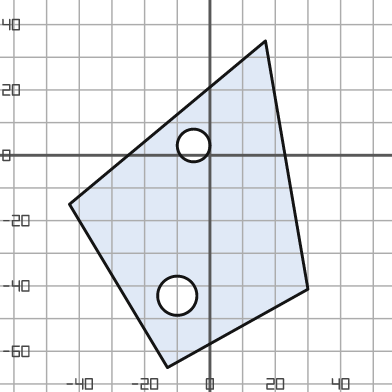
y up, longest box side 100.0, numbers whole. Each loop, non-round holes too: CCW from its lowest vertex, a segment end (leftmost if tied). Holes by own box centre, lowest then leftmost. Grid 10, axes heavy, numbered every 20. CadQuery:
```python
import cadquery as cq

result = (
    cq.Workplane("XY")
    .moveTo(-13.0, -65.0)
    .lineTo(30.0, -41.0)
    .lineTo(17.0, 35.0)
    .lineTo(-43.0, -15.0)
    .close()
    .moveTo(-10.0, -43.0)
    .circle(6.0)
    .moveTo(-5.0, 3.0)
    .circle(5.0)
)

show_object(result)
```